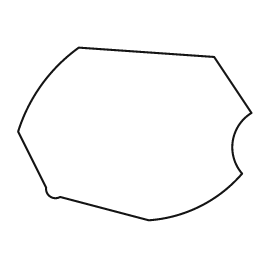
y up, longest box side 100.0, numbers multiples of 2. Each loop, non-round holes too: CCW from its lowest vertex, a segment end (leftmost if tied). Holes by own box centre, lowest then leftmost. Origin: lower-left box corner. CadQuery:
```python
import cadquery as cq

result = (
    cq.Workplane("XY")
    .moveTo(56.0, 0.0)
    .threePointArc((78.0, 6.0), (96.0, 20.0))
    .threePointArc((92.0, 34.0), (100.0, 46.0))
    .lineTo(84.0, 70.0)
    .lineTo(26.0, 74.0)
    .threePointArc((10.0, 58.0), (0.0, 38.0))
    .lineTo(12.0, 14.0)
    .threePointArc((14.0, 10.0), (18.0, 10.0))
    .close()
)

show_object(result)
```